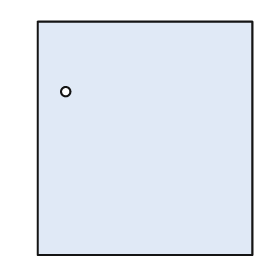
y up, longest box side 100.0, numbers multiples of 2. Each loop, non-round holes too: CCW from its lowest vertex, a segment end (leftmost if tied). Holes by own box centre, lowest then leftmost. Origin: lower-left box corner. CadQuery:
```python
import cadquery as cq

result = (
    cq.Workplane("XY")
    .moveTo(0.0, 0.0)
    .lineTo(92.0, 0.0)
    .lineTo(92.0, 100.0)
    .lineTo(0.0, 100.0)
    .close()
    .moveTo(12.0, 70.0)
    .circle(2.0)
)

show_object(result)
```